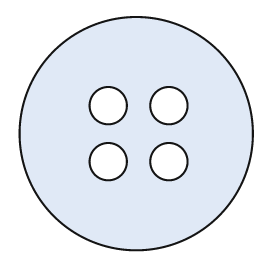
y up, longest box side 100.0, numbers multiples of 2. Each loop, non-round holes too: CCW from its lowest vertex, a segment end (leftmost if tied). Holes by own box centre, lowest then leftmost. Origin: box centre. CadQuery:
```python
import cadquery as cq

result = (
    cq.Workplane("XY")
    .moveTo(0.0, 0.0)
    .circle(50.0)
    .moveTo(-12.0, -12.0)
    .circle(8.0)
    .moveTo(14.0, -12.0)
    .circle(8.0)
    .moveTo(-12.0, 12.0)
    .circle(8.0)
    .moveTo(14.0, 12.0)
    .circle(8.0)
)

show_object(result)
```